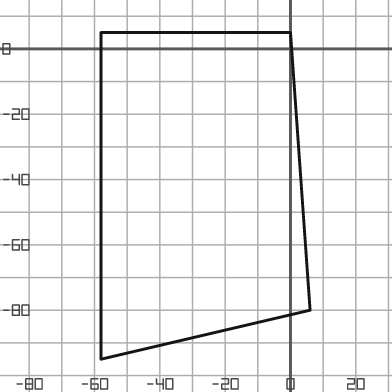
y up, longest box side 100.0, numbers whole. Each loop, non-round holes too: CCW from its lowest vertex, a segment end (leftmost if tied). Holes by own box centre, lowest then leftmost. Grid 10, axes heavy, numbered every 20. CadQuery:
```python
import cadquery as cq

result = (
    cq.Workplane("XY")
    .moveTo(-58.0, -95.0)
    .lineTo(6.0, -80.0)
    .lineTo(0.0, 5.0)
    .lineTo(-58.0, 5.0)
    .close()
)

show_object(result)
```